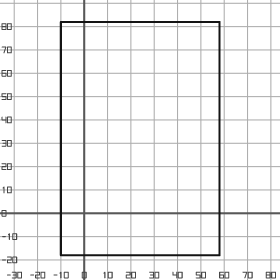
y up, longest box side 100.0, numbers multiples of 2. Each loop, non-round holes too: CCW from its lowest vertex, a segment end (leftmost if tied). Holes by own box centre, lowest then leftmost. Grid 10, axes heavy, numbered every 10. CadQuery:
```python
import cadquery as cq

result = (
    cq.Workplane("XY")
    .moveTo(-10.0, -18.0)
    .lineTo(58.0, -18.0)
    .lineTo(58.0, 82.0)
    .lineTo(-10.0, 82.0)
    .close()
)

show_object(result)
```